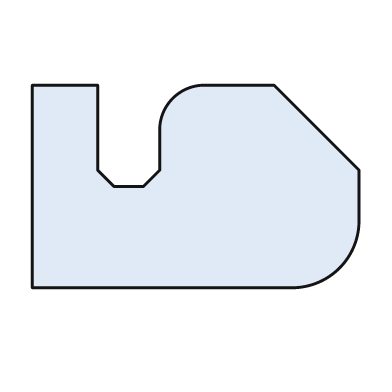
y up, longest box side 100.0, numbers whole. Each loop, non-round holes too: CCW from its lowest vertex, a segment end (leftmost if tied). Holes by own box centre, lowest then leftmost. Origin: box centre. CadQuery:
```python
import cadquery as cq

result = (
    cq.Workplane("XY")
    .moveTo(-50.0, -31.0)
    .lineTo(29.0, -31.0)
    .threePointArc((44.0, -25.0), (50.0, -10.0))
    .lineTo(50.0, 5.0)
    .lineTo(24.0, 31.0)
    .lineTo(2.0, 31.0)
    .threePointArc((-7.0, 27.0), (-11.0, 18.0))
    .lineTo(-11.0, 5.0)
    .lineTo(-16.0, 0.0)
    .lineTo(-25.0, 0.0)
    .lineTo(-30.0, 5.0)
    .lineTo(-30.0, 31.0)
    .lineTo(-50.0, 31.0)
    .close()
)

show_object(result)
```